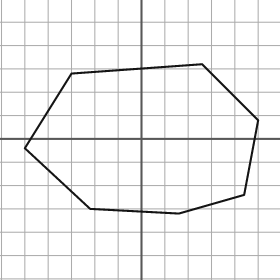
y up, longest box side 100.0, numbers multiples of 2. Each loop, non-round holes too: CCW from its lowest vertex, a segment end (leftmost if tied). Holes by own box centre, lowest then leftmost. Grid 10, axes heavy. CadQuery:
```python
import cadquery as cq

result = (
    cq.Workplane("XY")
    .moveTo(16.0, -32.0)
    .lineTo(44.0, -24.0)
    .lineTo(50.0, 8.0)
    .lineTo(26.0, 32.0)
    .lineTo(-30.0, 28.0)
    .lineTo(-50.0, -4.0)
    .lineTo(-22.0, -30.0)
    .close()
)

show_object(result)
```